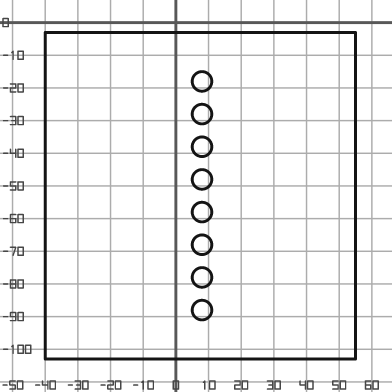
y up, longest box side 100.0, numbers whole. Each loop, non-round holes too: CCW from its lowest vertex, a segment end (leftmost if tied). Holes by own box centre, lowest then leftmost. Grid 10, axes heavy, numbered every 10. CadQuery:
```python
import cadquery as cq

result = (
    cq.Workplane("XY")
    .moveTo(-40.0, -103.0)
    .lineTo(55.0, -103.0)
    .lineTo(55.0, -3.0)
    .lineTo(-40.0, -3.0)
    .close()
    .moveTo(8.0, -88.0)
    .circle(3.0)
    .moveTo(8.0, -78.0)
    .circle(3.0)
    .moveTo(8.0, -68.0)
    .circle(3.0)
    .moveTo(8.0, -58.0)
    .circle(3.0)
    .moveTo(8.0, -48.0)
    .circle(3.0)
    .moveTo(8.0, -38.0)
    .circle(3.0)
    .moveTo(8.0, -28.0)
    .circle(3.0)
    .moveTo(8.0, -18.0)
    .circle(3.0)
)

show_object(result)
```